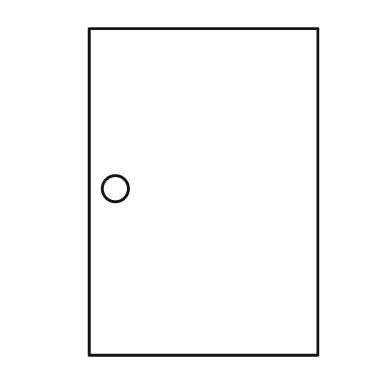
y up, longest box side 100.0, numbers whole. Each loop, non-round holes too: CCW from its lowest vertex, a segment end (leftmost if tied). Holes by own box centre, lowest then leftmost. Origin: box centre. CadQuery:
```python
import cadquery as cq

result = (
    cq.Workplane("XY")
    .moveTo(-35.0, -50.0)
    .lineTo(35.0, -50.0)
    .lineTo(35.0, 50.0)
    .lineTo(-35.0, 50.0)
    .close()
    .moveTo(-27.0, 1.0)
    .circle(4.0)
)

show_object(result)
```